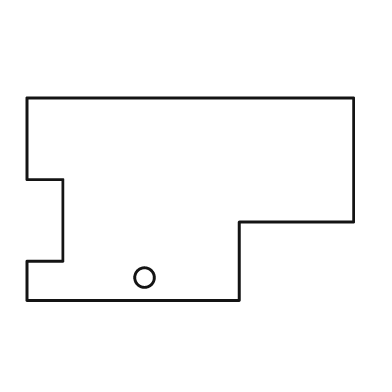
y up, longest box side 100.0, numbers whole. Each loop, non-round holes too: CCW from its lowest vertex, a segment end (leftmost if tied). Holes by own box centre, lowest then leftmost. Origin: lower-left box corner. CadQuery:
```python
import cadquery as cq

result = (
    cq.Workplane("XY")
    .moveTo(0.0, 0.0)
    .lineTo(65.0, 0.0)
    .lineTo(65.0, 24.0)
    .lineTo(100.0, 24.0)
    .lineTo(100.0, 62.0)
    .lineTo(0.0, 62.0)
    .lineTo(0.0, 37.0)
    .lineTo(11.0, 37.0)
    .lineTo(11.0, 12.0)
    .lineTo(0.0, 12.0)
    .close()
    .moveTo(36.0, 7.0)
    .circle(3.0)
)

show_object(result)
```